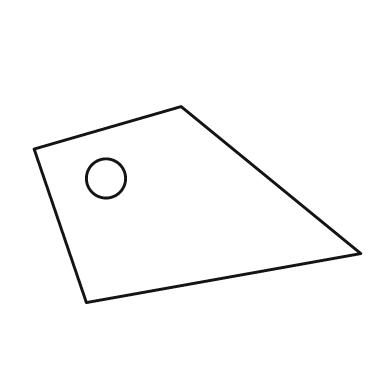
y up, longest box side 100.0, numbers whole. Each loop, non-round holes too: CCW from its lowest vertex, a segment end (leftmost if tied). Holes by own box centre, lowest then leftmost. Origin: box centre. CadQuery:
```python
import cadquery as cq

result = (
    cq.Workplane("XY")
    .moveTo(-34.0, -30.0)
    .lineTo(50.0, -15.0)
    .lineTo(-5.0, 30.0)
    .lineTo(-50.0, 17.0)
    .close()
    .moveTo(-28.0, 8.0)
    .circle(6.0)
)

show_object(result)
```